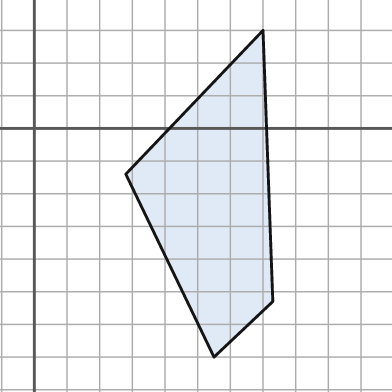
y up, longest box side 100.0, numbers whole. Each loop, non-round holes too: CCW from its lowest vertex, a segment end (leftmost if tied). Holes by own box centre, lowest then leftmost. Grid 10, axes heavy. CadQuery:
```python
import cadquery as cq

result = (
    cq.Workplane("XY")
    .moveTo(55.0, -70.0)
    .lineTo(73.0, -53.0)
    .lineTo(70.0, 30.0)
    .lineTo(28.0, -14.0)
    .close()
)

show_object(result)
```